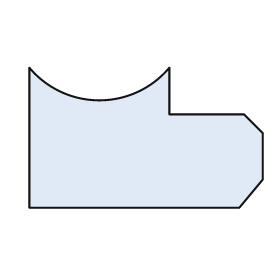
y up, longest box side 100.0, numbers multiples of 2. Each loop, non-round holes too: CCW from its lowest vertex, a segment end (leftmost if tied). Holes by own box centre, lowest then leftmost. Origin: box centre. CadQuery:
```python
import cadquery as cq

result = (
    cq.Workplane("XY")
    .moveTo(-50.0, -30.0)
    .lineTo(40.0, -30.0)
    .lineTo(50.0, -18.0)
    .lineTo(50.0, 2.0)
    .lineTo(42.0, 10.0)
    .lineTo(10.0, 10.0)
    .lineTo(10.0, 30.0)
    .threePointArc((-20.0, 16.0), (-50.0, 30.0))
    .close()
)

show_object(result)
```